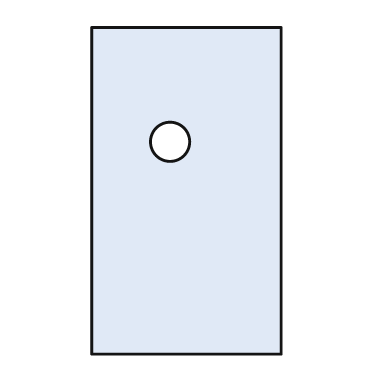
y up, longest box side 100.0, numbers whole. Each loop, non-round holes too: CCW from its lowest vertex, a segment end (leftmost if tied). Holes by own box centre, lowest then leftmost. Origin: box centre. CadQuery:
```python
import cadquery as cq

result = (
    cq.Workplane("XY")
    .moveTo(-29.0, -50.0)
    .lineTo(29.0, -50.0)
    .lineTo(29.0, 50.0)
    .lineTo(-29.0, 50.0)
    .close()
    .moveTo(-5.0, 15.0)
    .circle(6.0)
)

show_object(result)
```